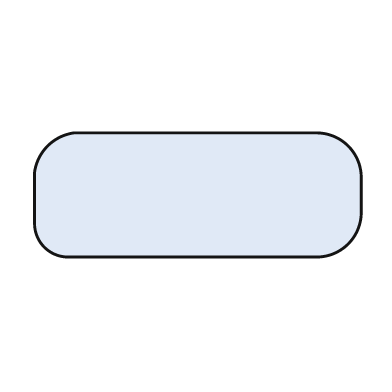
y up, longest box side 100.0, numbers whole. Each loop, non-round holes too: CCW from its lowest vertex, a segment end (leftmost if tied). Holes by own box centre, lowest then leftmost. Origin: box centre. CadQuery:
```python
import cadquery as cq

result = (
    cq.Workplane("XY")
    .moveTo(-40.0, -19.0)
    .lineTo(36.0, -19.0)
    .threePointArc((46.0, -15.0), (50.0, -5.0))
    .lineTo(50.0, 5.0)
    .threePointArc((46.0, 15.0), (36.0, 19.0))
    .lineTo(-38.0, 19.0)
    .threePointArc((-46.0, 15.0), (-50.0, 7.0))
    .lineTo(-50.0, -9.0)
    .threePointArc((-47.0, -16.0), (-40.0, -19.0))
    .close()
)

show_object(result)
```